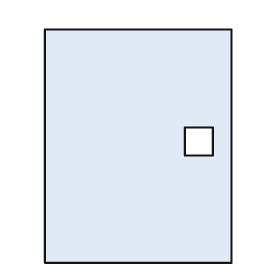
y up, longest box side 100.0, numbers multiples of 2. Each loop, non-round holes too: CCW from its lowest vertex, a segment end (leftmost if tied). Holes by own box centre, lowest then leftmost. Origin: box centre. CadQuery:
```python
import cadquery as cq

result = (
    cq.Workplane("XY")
    .moveTo(-40.0, -50.0)
    .lineTo(40.0, -50.0)
    .lineTo(40.0, 50.0)
    .lineTo(-40.0, 50.0)
    .close()
    .moveTo(20.0, -4.0)
    .lineTo(32.0, -4.0)
    .lineTo(32.0, 8.0)
    .lineTo(20.0, 8.0)
    .close()
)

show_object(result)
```